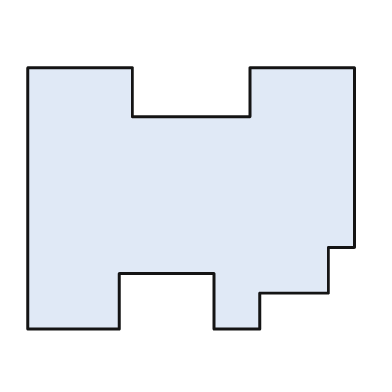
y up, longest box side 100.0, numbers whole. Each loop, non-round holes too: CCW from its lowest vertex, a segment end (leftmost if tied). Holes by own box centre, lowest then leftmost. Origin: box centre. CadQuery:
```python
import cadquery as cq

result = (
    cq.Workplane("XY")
    .moveTo(-50.0, -40.0)
    .lineTo(-22.0, -40.0)
    .lineTo(-22.0, -23.0)
    .lineTo(7.0, -23.0)
    .lineTo(7.0, -40.0)
    .lineTo(21.0, -40.0)
    .lineTo(21.0, -29.0)
    .lineTo(42.0, -29.0)
    .lineTo(42.0, -15.0)
    .lineTo(50.0, -15.0)
    .lineTo(50.0, 40.0)
    .lineTo(18.0, 40.0)
    .lineTo(18.0, 25.0)
    .lineTo(-18.0, 25.0)
    .lineTo(-18.0, 40.0)
    .lineTo(-50.0, 40.0)
    .close()
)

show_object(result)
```